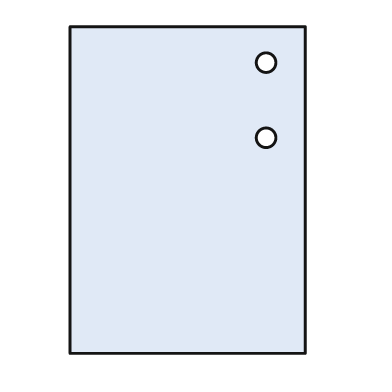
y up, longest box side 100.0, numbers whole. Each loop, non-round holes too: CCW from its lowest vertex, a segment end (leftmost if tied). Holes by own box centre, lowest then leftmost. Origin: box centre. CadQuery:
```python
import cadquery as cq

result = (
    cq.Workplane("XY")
    .moveTo(-36.0, -50.0)
    .lineTo(36.0, -50.0)
    .lineTo(36.0, 50.0)
    .lineTo(-36.0, 50.0)
    .close()
    .moveTo(24.0, 16.0)
    .circle(3.0)
    .moveTo(24.0, 39.0)
    .circle(3.0)
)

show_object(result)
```